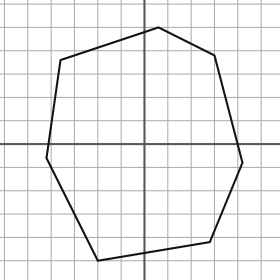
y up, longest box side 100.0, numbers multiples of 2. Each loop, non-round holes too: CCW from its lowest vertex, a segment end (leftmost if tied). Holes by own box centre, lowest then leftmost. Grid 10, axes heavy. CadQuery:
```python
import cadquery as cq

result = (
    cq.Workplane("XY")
    .moveTo(-20.0, -50.0)
    .lineTo(28.0, -42.0)
    .lineTo(42.0, -8.0)
    .lineTo(30.0, 38.0)
    .lineTo(6.0, 50.0)
    .lineTo(-36.0, 36.0)
    .lineTo(-42.0, -6.0)
    .close()
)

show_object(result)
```